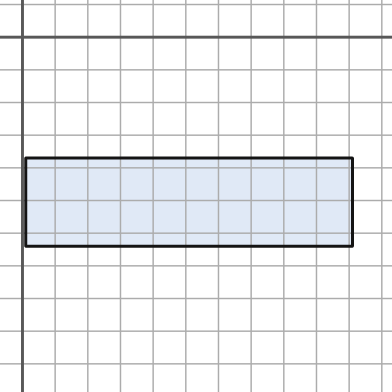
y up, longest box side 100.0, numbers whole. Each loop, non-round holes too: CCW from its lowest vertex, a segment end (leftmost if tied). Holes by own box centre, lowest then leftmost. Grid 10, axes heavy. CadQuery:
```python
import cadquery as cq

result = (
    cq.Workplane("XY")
    .moveTo(1.0, -64.0)
    .lineTo(101.0, -64.0)
    .lineTo(101.0, -37.0)
    .lineTo(1.0, -37.0)
    .close()
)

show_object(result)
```